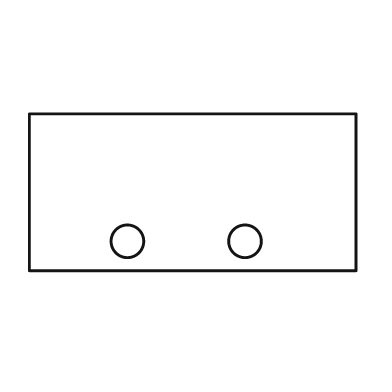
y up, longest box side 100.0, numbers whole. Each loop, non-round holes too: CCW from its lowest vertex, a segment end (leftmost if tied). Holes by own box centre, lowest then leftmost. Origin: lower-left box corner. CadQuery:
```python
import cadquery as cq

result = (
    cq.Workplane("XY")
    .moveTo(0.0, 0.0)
    .lineTo(100.0, 0.0)
    .lineTo(100.0, 48.0)
    .lineTo(0.0, 48.0)
    .close()
    .moveTo(30.0, 9.0)
    .circle(5.0)
    .moveTo(66.0, 9.0)
    .circle(5.0)
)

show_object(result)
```